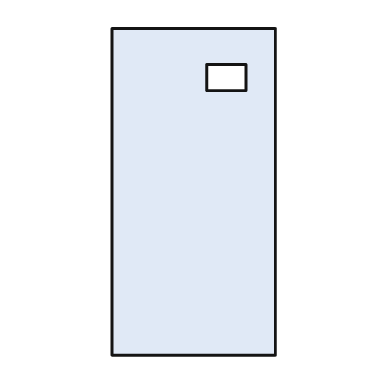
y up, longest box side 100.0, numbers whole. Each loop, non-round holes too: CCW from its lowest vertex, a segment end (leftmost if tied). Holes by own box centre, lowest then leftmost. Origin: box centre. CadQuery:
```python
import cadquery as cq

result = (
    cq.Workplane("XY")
    .moveTo(-25.0, -50.0)
    .lineTo(25.0, -50.0)
    .lineTo(25.0, 50.0)
    .lineTo(-25.0, 50.0)
    .close()
    .moveTo(4.0, 31.0)
    .lineTo(16.0, 31.0)
    .lineTo(16.0, 39.0)
    .lineTo(4.0, 39.0)
    .close()
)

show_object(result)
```